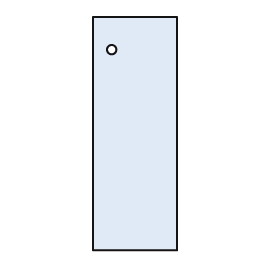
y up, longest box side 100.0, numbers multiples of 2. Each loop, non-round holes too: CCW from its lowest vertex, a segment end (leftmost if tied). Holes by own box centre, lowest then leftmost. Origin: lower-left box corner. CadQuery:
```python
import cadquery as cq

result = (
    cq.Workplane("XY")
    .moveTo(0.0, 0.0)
    .lineTo(36.0, 0.0)
    .lineTo(36.0, 100.0)
    .lineTo(0.0, 100.0)
    .close()
    .moveTo(8.0, 86.0)
    .circle(2.0)
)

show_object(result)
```